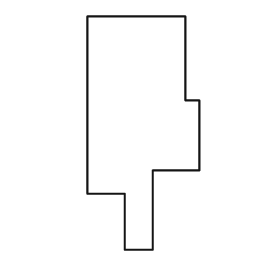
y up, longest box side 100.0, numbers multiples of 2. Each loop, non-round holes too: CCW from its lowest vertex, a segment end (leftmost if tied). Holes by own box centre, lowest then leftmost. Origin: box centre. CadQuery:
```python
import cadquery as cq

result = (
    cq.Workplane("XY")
    .moveTo(-8.0, -50.0)
    .lineTo(4.0, -50.0)
    .lineTo(4.0, -16.0)
    .lineTo(24.0, -16.0)
    .lineTo(24.0, 14.0)
    .lineTo(18.0, 14.0)
    .lineTo(18.0, 50.0)
    .lineTo(-24.0, 50.0)
    .lineTo(-24.0, -26.0)
    .lineTo(-8.0, -26.0)
    .close()
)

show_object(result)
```